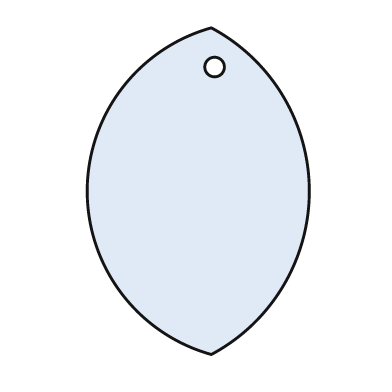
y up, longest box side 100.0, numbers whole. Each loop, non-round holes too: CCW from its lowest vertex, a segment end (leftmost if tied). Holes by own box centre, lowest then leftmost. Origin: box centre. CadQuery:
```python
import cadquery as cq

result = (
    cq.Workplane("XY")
    .moveTo(4.0, -50.0)
    .threePointArc((34.0, 0.0), (4.0, 50.0))
    .threePointArc((-34.0, 0.0), (4.0, -50.0))
    .close()
    .moveTo(5.0, 38.0)
    .circle(3.0)
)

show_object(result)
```